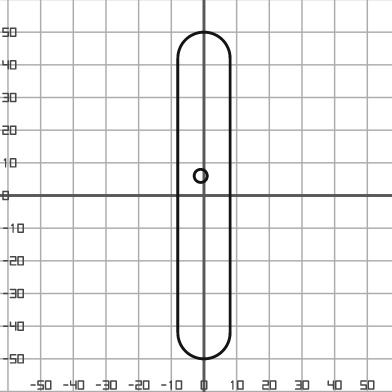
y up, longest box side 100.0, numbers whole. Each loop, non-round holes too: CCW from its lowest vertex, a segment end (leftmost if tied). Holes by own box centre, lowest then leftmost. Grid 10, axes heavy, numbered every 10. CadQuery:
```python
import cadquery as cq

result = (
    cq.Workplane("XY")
    .moveTo(-8.0, -42.0)
    .threePointArc((0.0, -50.0), (8.0, -42.0))
    .lineTo(8.0, 42.0)
    .threePointArc((0.0, 50.0), (-8.0, 42.0))
    .close()
    .moveTo(-1.0, 6.0)
    .circle(2.0)
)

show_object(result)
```